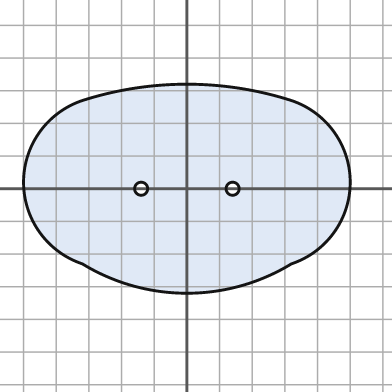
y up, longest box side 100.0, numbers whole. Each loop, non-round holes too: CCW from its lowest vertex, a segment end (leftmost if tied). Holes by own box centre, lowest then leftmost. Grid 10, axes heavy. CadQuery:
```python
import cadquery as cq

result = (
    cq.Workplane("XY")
    .moveTo(-32.0, -23.0)
    .threePointArc((0.0, -32.0), (32.0, -23.0))
    .threePointArc((50.0, 2.0), (32.0, 27.0))
    .threePointArc((0.0, 32.0), (-32.0, 27.0))
    .threePointArc((-50.0, 2.0), (-32.0, -23.0))
    .close()
    .moveTo(-14.0, 0.0)
    .circle(2.0)
    .moveTo(14.0, 0.0)
    .circle(2.0)
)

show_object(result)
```